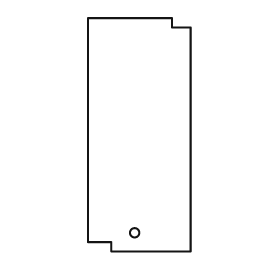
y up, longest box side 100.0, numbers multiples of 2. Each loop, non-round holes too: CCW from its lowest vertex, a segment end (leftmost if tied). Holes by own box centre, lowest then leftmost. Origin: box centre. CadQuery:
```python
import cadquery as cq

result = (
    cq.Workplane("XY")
    .moveTo(-12.0, -50.0)
    .lineTo(22.0, -50.0)
    .lineTo(22.0, 46.0)
    .lineTo(14.0, 46.0)
    .lineTo(14.0, 50.0)
    .lineTo(-22.0, 50.0)
    .lineTo(-22.0, -46.0)
    .lineTo(-12.0, -46.0)
    .close()
    .moveTo(-2.0, -42.0)
    .circle(2.0)
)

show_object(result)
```